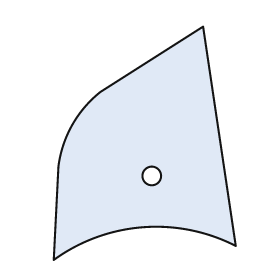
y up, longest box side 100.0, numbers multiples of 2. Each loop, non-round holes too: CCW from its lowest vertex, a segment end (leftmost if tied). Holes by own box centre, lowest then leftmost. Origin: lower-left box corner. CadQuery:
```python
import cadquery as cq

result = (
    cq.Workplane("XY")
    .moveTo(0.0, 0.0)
    .threePointArc((38.0, 14.0), (78.0, 6.0))
    .lineTo(64.0, 100.0)
    .lineTo(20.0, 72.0)
    .threePointArc((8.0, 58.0), (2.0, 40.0))
    .close()
    .moveTo(42.0, 36.0)
    .circle(4.0)
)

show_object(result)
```